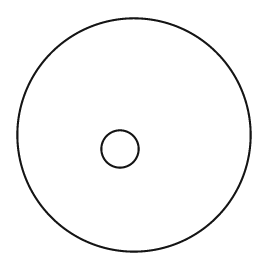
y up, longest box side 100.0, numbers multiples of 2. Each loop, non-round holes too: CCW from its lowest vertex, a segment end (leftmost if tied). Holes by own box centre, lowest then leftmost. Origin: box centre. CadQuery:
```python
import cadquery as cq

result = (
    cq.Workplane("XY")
    .moveTo(0.0, 0.0)
    .circle(50.0)
    .moveTo(-6.0, -6.0)
    .circle(8.0)
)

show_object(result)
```